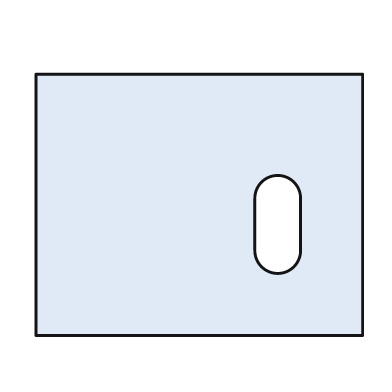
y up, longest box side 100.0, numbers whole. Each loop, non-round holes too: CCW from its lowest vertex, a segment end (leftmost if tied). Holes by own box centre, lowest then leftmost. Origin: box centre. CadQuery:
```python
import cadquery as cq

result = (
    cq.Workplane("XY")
    .moveTo(-50.0, -40.0)
    .lineTo(50.0, -40.0)
    .lineTo(50.0, 40.0)
    .lineTo(-50.0, 40.0)
    .close()
    .moveTo(17.0, -14.0)
    .threePointArc((24.0, -21.0), (31.0, -14.0))
    .lineTo(31.0, 2.0)
    .threePointArc((24.0, 9.0), (17.0, 2.0))
    .close()
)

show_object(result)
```